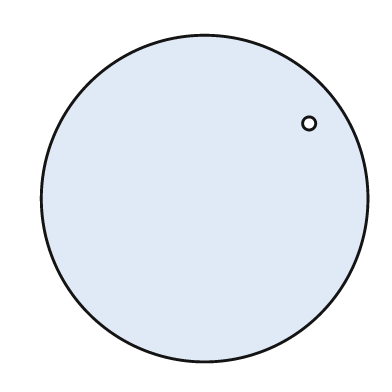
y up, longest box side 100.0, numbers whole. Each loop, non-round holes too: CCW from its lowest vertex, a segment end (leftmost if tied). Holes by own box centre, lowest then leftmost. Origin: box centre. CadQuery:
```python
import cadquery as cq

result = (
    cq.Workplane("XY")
    .moveTo(0.0, 0.0)
    .circle(50.0)
    .moveTo(32.0, 23.0)
    .circle(2.0)
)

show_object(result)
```